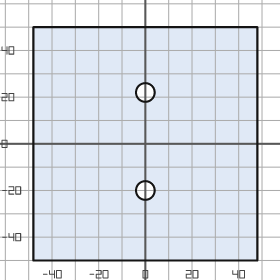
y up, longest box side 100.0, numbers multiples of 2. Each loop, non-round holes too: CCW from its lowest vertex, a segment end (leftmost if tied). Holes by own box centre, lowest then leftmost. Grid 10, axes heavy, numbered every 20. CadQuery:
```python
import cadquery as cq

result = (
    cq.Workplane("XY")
    .moveTo(-48.0, -50.0)
    .lineTo(48.0, -50.0)
    .lineTo(48.0, 50.0)
    .lineTo(-48.0, 50.0)
    .close()
    .moveTo(0.0, -20.0)
    .circle(4.0)
    .moveTo(0.0, 22.0)
    .circle(4.0)
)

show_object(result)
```